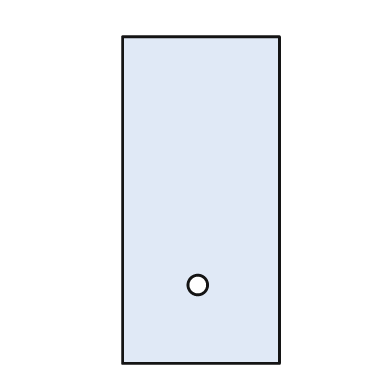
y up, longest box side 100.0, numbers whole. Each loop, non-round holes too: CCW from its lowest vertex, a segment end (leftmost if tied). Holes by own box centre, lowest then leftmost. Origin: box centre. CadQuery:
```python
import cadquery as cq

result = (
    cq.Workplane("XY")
    .moveTo(-24.0, -50.0)
    .lineTo(24.0, -50.0)
    .lineTo(24.0, 50.0)
    .lineTo(-24.0, 50.0)
    .close()
    .moveTo(-1.0, -26.0)
    .circle(3.0)
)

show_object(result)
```